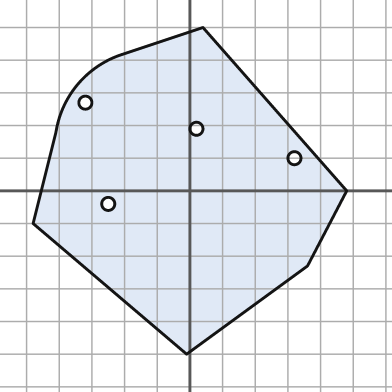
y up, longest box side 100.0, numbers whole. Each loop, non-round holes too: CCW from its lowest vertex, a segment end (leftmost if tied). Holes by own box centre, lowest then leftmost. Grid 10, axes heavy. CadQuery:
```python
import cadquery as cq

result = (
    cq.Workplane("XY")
    .moveTo(-1.0, -50.0)
    .lineTo(36.0, -23.0)
    .lineTo(48.0, 0.0)
    .lineTo(4.0, 50.0)
    .lineTo(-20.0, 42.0)
    .threePointArc((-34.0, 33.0), (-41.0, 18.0))
    .lineTo(-48.0, -10.0)
    .close()
    .moveTo(-25.0, -4.0)
    .circle(2.0)
    .moveTo(32.0, 10.0)
    .circle(2.0)
    .moveTo(2.0, 19.0)
    .circle(2.0)
    .moveTo(-32.0, 27.0)
    .circle(2.0)
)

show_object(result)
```